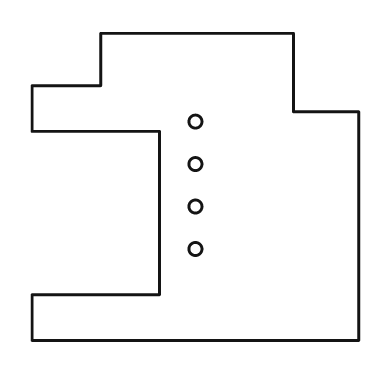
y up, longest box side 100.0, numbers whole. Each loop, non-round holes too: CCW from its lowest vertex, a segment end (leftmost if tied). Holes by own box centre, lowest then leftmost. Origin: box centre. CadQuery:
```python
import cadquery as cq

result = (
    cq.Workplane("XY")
    .moveTo(-50.0, -47.0)
    .lineTo(50.0, -47.0)
    .lineTo(50.0, 23.0)
    .lineTo(30.0, 23.0)
    .lineTo(30.0, 47.0)
    .lineTo(-29.0, 47.0)
    .lineTo(-29.0, 31.0)
    .lineTo(-50.0, 31.0)
    .lineTo(-50.0, 17.0)
    .lineTo(-11.0, 17.0)
    .lineTo(-11.0, -33.0)
    .lineTo(-50.0, -33.0)
    .close()
    .moveTo(0.0, -19.0)
    .circle(2.0)
    .moveTo(0.0, -6.0)
    .circle(2.0)
    .moveTo(0.0, 7.0)
    .circle(2.0)
    .moveTo(0.0, 20.0)
    .circle(2.0)
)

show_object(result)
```